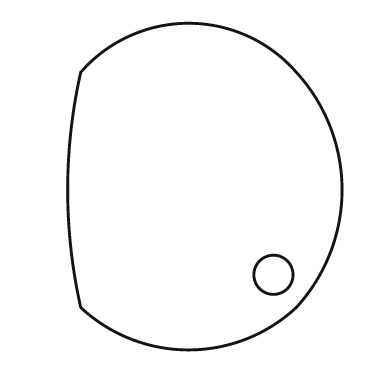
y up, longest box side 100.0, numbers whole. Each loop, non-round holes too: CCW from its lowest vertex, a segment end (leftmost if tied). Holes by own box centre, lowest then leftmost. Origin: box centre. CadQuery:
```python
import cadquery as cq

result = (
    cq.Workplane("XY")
    .moveTo(-38.0, -37.0)
    .threePointArc((-5.0, -50.0), (28.0, -37.0))
    .threePointArc((42.0, -1.0), (28.0, 35.0))
    .threePointArc((-5.0, 50.0), (-38.0, 35.0))
    .threePointArc((-42.0, -1.0), (-38.0, -37.0))
    .close()
    .moveTo(21.0, -27.0)
    .circle(6.0)
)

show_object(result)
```